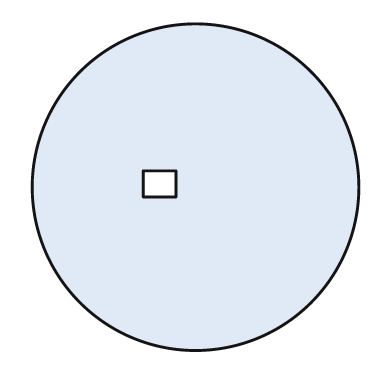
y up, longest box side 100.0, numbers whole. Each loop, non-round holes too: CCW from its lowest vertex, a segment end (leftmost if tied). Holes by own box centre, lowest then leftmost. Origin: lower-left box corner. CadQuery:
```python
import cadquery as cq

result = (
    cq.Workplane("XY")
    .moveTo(50.0, 50.0)
    .circle(50.0)
    .moveTo(34.0, 47.0)
    .lineTo(44.0, 47.0)
    .lineTo(44.0, 55.0)
    .lineTo(34.0, 55.0)
    .close()
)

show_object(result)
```